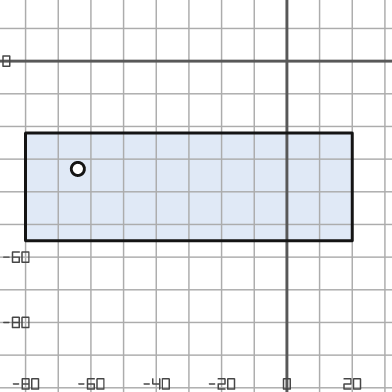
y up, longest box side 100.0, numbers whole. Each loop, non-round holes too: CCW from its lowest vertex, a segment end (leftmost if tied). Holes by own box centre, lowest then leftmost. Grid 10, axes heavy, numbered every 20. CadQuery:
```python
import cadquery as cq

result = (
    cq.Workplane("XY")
    .moveTo(-80.0, -55.0)
    .lineTo(20.0, -55.0)
    .lineTo(20.0, -22.0)
    .lineTo(-80.0, -22.0)
    .close()
    .moveTo(-64.0, -33.0)
    .circle(2.0)
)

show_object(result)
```